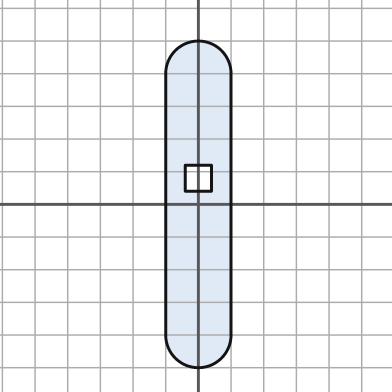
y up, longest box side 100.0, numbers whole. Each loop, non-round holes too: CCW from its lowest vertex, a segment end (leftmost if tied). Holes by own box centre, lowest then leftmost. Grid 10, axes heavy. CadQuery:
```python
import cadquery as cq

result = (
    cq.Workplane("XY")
    .moveTo(-10.0, -40.0)
    .threePointArc((0.0, -50.0), (10.0, -40.0))
    .lineTo(10.0, 40.0)
    .threePointArc((0.0, 50.0), (-10.0, 40.0))
    .close()
    .moveTo(-4.0, 4.0)
    .lineTo(4.0, 4.0)
    .lineTo(4.0, 12.0)
    .lineTo(-4.0, 12.0)
    .close()
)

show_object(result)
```